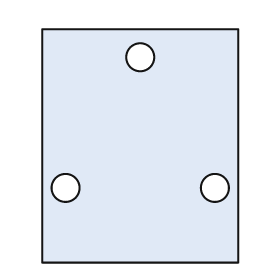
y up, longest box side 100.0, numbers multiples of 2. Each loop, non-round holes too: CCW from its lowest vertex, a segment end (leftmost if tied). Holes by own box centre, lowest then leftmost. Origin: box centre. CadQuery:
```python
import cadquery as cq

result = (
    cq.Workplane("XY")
    .moveTo(-42.0, -50.0)
    .lineTo(42.0, -50.0)
    .lineTo(42.0, 50.0)
    .lineTo(-42.0, 50.0)
    .close()
    .moveTo(-32.0, -18.0)
    .circle(6.0)
    .moveTo(32.0, -18.0)
    .circle(6.0)
    .moveTo(0.0, 38.0)
    .circle(6.0)
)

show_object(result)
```